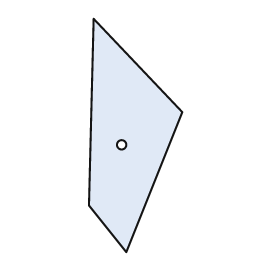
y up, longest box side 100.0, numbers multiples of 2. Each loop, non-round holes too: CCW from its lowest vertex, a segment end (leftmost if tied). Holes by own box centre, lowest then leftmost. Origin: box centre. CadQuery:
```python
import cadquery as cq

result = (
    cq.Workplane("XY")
    .moveTo(-4.0, -50.0)
    .lineTo(20.0, 10.0)
    .lineTo(-18.0, 50.0)
    .lineTo(-20.0, -30.0)
    .close()
    .moveTo(-6.0, -4.0)
    .circle(2.0)
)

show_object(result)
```